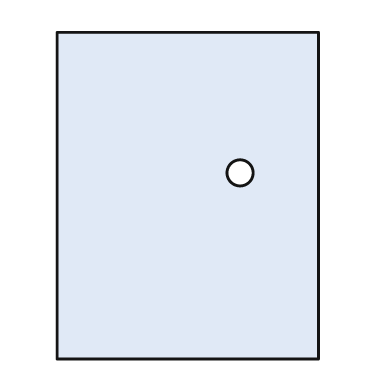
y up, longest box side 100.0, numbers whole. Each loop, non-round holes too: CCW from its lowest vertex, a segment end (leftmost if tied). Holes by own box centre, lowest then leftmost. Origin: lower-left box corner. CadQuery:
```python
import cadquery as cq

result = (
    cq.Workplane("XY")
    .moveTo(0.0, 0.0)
    .lineTo(80.0, 0.0)
    .lineTo(80.0, 100.0)
    .lineTo(0.0, 100.0)
    .close()
    .moveTo(56.0, 57.0)
    .circle(4.0)
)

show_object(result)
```